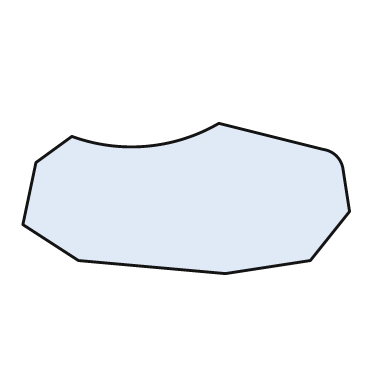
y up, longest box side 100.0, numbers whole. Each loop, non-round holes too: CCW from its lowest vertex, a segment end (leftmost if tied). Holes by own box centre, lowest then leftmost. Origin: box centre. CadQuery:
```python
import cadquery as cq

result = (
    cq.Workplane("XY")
    .moveTo(12.0, -23.0)
    .lineTo(38.0, -19.0)
    .lineTo(50.0, -4.0)
    .lineTo(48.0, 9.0)
    .threePointArc((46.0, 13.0), (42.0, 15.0))
    .lineTo(10.0, 23.0)
    .threePointArc((-12.0, 16.0), (-35.0, 19.0))
    .lineTo(-46.0, 11.0)
    .lineTo(-50.0, -8.0)
    .lineTo(-33.0, -19.0)
    .close()
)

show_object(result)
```